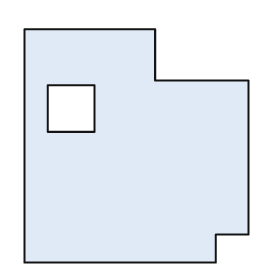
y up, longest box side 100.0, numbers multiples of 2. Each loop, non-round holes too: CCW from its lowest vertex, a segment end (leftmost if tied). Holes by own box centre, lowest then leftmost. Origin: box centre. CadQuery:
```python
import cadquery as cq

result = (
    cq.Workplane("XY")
    .moveTo(-48.0, -50.0)
    .lineTo(34.0, -50.0)
    .lineTo(34.0, -38.0)
    .lineTo(48.0, -38.0)
    .lineTo(48.0, 28.0)
    .lineTo(8.0, 28.0)
    .lineTo(8.0, 50.0)
    .lineTo(-48.0, 50.0)
    .close()
    .moveTo(-38.0, 6.0)
    .lineTo(-18.0, 6.0)
    .lineTo(-18.0, 26.0)
    .lineTo(-38.0, 26.0)
    .close()
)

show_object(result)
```